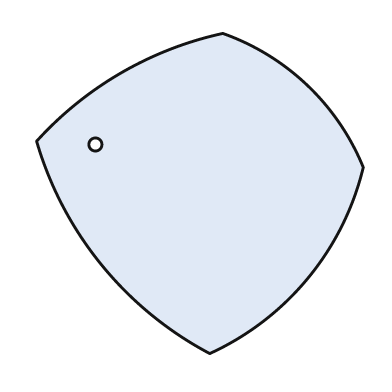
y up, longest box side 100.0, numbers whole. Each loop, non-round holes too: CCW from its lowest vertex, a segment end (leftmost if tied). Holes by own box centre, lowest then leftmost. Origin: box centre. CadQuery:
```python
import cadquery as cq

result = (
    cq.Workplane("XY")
    .moveTo(3.0, -49.0)
    .threePointArc((33.0, -26.0), (50.0, 8.0))
    .threePointArc((33.0, 33.0), (7.0, 49.0))
    .threePointArc((-24.0, 37.0), (-50.0, 16.0))
    .threePointArc((-30.0, -22.0), (3.0, -49.0))
    .close()
    .moveTo(-32.0, 15.0)
    .circle(2.0)
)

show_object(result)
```